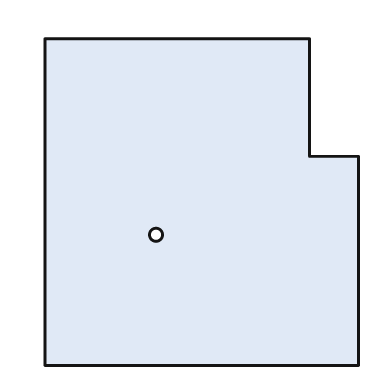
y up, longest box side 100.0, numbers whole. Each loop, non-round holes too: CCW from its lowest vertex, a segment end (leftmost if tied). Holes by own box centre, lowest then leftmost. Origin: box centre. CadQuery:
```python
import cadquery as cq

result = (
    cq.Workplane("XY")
    .moveTo(-48.0, -50.0)
    .lineTo(48.0, -50.0)
    .lineTo(48.0, 14.0)
    .lineTo(33.0, 14.0)
    .lineTo(33.0, 50.0)
    .lineTo(-48.0, 50.0)
    .close()
    .moveTo(-14.0, -10.0)
    .circle(2.0)
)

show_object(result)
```